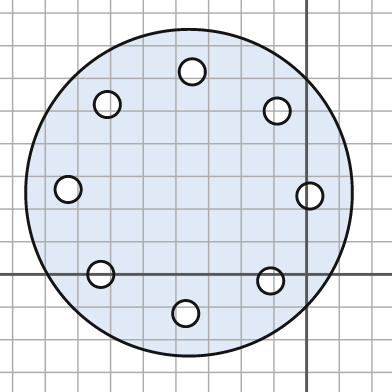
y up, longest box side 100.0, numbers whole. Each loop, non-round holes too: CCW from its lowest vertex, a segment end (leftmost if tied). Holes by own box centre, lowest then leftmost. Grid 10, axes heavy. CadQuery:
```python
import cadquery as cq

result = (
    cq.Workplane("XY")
    .moveTo(-36.0, 25.0)
    .circle(50.0)
    .moveTo(-37.0, -12.0)
    .circle(4.0)
    .moveTo(-11.0, -2.0)
    .circle(4.0)
    .moveTo(-63.0, 0.0)
    .circle(4.0)
    .moveTo(1.0, 24.0)
    .circle(4.0)
    .moveTo(-73.0, 26.0)
    .circle(4.0)
    .moveTo(-9.0, 50.0)
    .circle(4.0)
    .moveTo(-61.0, 52.0)
    .circle(4.0)
    .moveTo(-35.0, 62.0)
    .circle(4.0)
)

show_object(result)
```